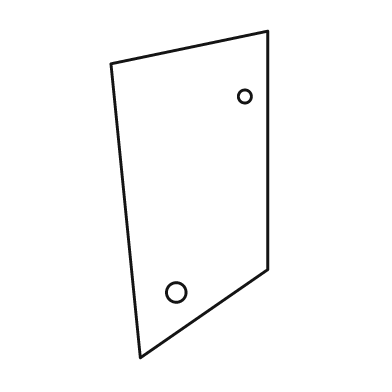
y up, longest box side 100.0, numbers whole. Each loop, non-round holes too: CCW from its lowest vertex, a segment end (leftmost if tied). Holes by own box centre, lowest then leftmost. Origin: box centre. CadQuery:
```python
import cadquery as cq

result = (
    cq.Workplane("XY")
    .moveTo(-15.0, -50.0)
    .lineTo(24.0, -23.0)
    .lineTo(24.0, 50.0)
    .lineTo(-24.0, 40.0)
    .close()
    .moveTo(-4.0, -30.0)
    .circle(3.0)
    .moveTo(17.0, 30.0)
    .circle(2.0)
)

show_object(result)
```